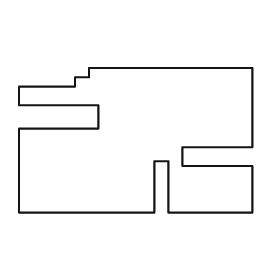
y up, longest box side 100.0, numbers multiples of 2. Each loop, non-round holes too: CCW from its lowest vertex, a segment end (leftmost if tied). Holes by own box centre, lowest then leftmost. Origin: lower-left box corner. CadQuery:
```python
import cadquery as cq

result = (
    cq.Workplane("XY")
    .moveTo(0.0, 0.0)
    .lineTo(58.0, 0.0)
    .lineTo(58.0, 22.0)
    .lineTo(64.0, 22.0)
    .lineTo(64.0, 0.0)
    .lineTo(100.0, 0.0)
    .lineTo(100.0, 20.0)
    .lineTo(70.0, 20.0)
    .lineTo(70.0, 28.0)
    .lineTo(100.0, 28.0)
    .lineTo(100.0, 62.0)
    .lineTo(30.0, 62.0)
    .lineTo(30.0, 58.0)
    .lineTo(24.0, 58.0)
    .lineTo(24.0, 54.0)
    .lineTo(0.0, 54.0)
    .lineTo(0.0, 46.0)
    .lineTo(34.0, 46.0)
    .lineTo(34.0, 36.0)
    .lineTo(0.0, 36.0)
    .close()
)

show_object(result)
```